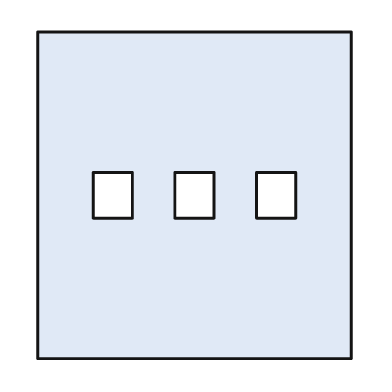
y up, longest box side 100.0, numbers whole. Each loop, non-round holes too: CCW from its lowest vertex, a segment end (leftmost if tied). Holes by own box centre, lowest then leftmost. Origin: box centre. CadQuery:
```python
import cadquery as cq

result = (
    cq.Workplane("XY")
    .moveTo(-48.0, -50.0)
    .lineTo(48.0, -50.0)
    .lineTo(48.0, 50.0)
    .lineTo(-48.0, 50.0)
    .close()
    .moveTo(-31.0, -7.0)
    .lineTo(-19.0, -7.0)
    .lineTo(-19.0, 7.0)
    .lineTo(-31.0, 7.0)
    .close()
    .moveTo(-6.0, -7.0)
    .lineTo(6.0, -7.0)
    .lineTo(6.0, 7.0)
    .lineTo(-6.0, 7.0)
    .close()
    .moveTo(19.0, -7.0)
    .lineTo(31.0, -7.0)
    .lineTo(31.0, 7.0)
    .lineTo(19.0, 7.0)
    .close()
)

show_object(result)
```